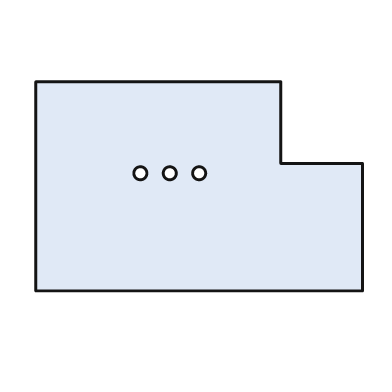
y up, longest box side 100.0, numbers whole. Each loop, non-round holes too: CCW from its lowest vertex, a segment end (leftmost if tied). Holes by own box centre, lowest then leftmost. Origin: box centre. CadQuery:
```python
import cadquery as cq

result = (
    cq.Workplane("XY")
    .moveTo(-50.0, -32.0)
    .lineTo(50.0, -32.0)
    .lineTo(50.0, 7.0)
    .lineTo(25.0, 7.0)
    .lineTo(25.0, 32.0)
    .lineTo(-50.0, 32.0)
    .close()
    .moveTo(-18.0, 4.0)
    .circle(2.0)
    .moveTo(-9.0, 4.0)
    .circle(2.0)
    .moveTo(0.0, 4.0)
    .circle(2.0)
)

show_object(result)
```